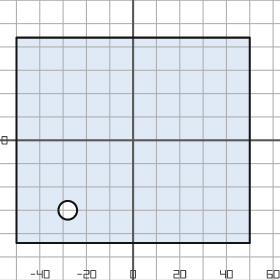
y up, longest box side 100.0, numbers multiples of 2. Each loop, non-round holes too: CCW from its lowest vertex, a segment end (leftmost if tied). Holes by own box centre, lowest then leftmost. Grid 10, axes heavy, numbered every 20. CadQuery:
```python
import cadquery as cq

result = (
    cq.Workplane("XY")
    .moveTo(-50.0, -44.0)
    .lineTo(50.0, -44.0)
    .lineTo(50.0, 44.0)
    .lineTo(-50.0, 44.0)
    .close()
    .moveTo(-28.0, -30.0)
    .circle(4.0)
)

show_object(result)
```